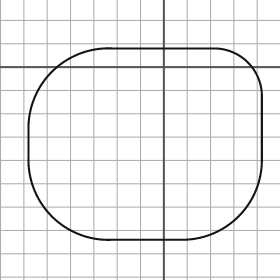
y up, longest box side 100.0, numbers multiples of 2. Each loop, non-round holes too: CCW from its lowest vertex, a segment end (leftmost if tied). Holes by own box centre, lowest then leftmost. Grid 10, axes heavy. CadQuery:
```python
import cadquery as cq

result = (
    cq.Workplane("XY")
    .moveTo(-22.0, -74.0)
    .lineTo(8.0, -74.0)
    .threePointArc((32.0, -64.0), (42.0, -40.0))
    .lineTo(42.0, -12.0)
    .threePointArc((36.0, 2.0), (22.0, 8.0))
    .lineTo(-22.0, 8.0)
    .threePointArc((-48.0, -2.0), (-58.0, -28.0))
    .lineTo(-58.0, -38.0)
    .threePointArc((-48.0, -64.0), (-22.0, -74.0))
    .close()
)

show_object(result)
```